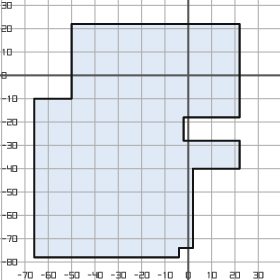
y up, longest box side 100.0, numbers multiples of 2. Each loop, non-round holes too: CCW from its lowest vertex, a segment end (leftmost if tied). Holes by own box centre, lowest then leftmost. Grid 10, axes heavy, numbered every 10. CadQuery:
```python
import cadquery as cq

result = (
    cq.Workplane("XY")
    .moveTo(-66.0, -78.0)
    .lineTo(-4.0, -78.0)
    .lineTo(-4.0, -74.0)
    .lineTo(2.0, -74.0)
    .lineTo(2.0, -40.0)
    .lineTo(22.0, -40.0)
    .lineTo(22.0, -28.0)
    .lineTo(-2.0, -28.0)
    .lineTo(-2.0, -18.0)
    .lineTo(22.0, -18.0)
    .lineTo(22.0, 22.0)
    .lineTo(-50.0, 22.0)
    .lineTo(-50.0, -10.0)
    .lineTo(-66.0, -10.0)
    .close()
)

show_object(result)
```